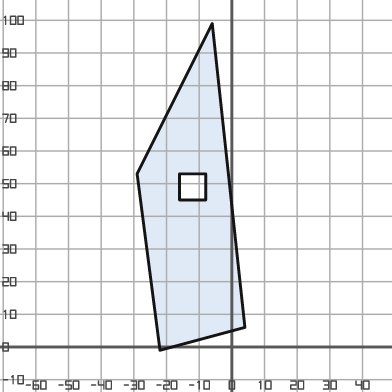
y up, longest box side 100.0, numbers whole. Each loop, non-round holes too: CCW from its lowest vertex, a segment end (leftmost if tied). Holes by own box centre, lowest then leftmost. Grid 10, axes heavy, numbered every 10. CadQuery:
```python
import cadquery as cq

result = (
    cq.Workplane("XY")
    .moveTo(-22.0, -1.0)
    .lineTo(4.0, 6.0)
    .lineTo(-6.0, 99.0)
    .lineTo(-29.0, 53.0)
    .close()
    .moveTo(-16.0, 45.0)
    .lineTo(-8.0, 45.0)
    .lineTo(-8.0, 53.0)
    .lineTo(-16.0, 53.0)
    .close()
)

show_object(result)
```